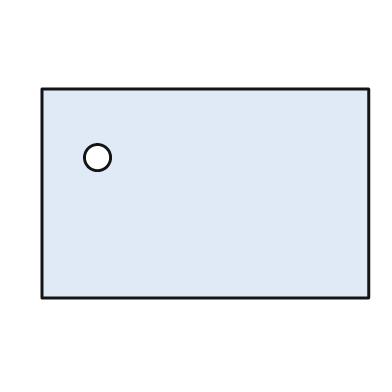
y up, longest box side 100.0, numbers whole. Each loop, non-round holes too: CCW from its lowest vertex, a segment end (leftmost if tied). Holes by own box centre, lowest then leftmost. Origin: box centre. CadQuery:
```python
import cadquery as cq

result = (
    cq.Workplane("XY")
    .moveTo(-50.0, -32.0)
    .lineTo(50.0, -32.0)
    .lineTo(50.0, 32.0)
    .lineTo(-50.0, 32.0)
    .close()
    .moveTo(-33.0, 11.0)
    .circle(4.0)
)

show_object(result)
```